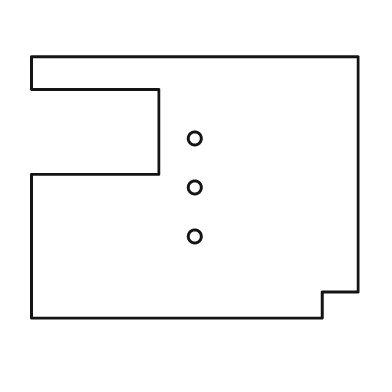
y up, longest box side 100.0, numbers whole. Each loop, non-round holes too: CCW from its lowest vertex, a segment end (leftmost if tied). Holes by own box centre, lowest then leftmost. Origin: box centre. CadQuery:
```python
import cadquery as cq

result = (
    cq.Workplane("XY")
    .moveTo(-50.0, -40.0)
    .lineTo(39.0, -40.0)
    .lineTo(39.0, -32.0)
    .lineTo(50.0, -32.0)
    .lineTo(50.0, 40.0)
    .lineTo(-50.0, 40.0)
    .lineTo(-50.0, 30.0)
    .lineTo(-11.0, 30.0)
    .lineTo(-11.0, 4.0)
    .lineTo(-50.0, 4.0)
    .close()
    .moveTo(0.0, -15.0)
    .circle(2.0)
    .moveTo(0.0, 0.0)
    .circle(2.0)
    .moveTo(0.0, 15.0)
    .circle(2.0)
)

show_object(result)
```